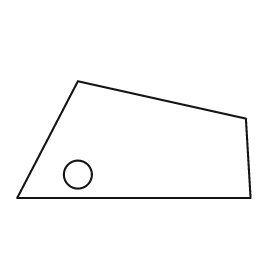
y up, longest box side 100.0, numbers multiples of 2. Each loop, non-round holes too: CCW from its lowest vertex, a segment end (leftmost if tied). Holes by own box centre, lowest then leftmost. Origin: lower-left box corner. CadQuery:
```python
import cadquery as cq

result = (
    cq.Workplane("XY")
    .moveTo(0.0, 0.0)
    .lineTo(100.0, 0.0)
    .lineTo(98.0, 34.0)
    .lineTo(26.0, 50.0)
    .close()
    .moveTo(26.0, 10.0)
    .circle(6.0)
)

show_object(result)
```